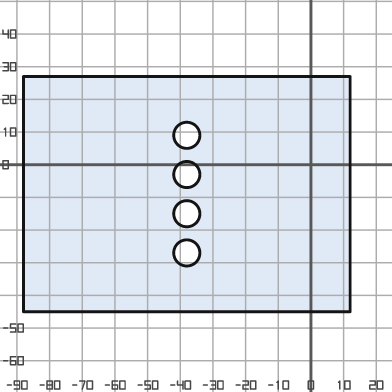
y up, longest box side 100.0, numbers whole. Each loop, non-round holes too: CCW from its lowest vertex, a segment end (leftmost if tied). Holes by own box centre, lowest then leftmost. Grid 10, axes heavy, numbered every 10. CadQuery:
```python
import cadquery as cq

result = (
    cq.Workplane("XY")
    .moveTo(-88.0, -45.0)
    .lineTo(12.0, -45.0)
    .lineTo(12.0, 27.0)
    .lineTo(-88.0, 27.0)
    .close()
    .moveTo(-38.0, -27.0)
    .circle(4.0)
    .moveTo(-38.0, -15.0)
    .circle(4.0)
    .moveTo(-38.0, -3.0)
    .circle(4.0)
    .moveTo(-38.0, 9.0)
    .circle(4.0)
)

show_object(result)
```